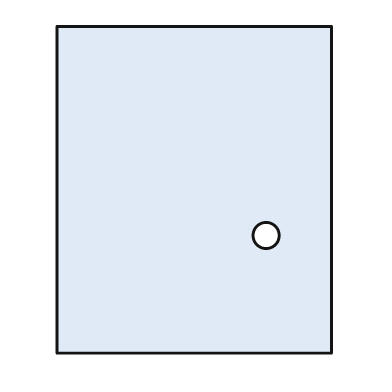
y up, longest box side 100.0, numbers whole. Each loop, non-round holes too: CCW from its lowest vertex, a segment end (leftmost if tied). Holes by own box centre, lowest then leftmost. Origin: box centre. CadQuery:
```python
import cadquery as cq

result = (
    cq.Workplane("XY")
    .moveTo(-42.0, -50.0)
    .lineTo(42.0, -50.0)
    .lineTo(42.0, 50.0)
    .lineTo(-42.0, 50.0)
    .close()
    .moveTo(22.0, -14.0)
    .circle(4.0)
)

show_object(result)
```